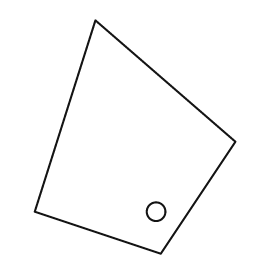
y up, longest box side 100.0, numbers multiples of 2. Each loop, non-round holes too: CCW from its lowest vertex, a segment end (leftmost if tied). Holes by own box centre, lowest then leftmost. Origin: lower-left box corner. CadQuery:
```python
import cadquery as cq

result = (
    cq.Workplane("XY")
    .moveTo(54.0, 0.0)
    .lineTo(86.0, 48.0)
    .lineTo(26.0, 100.0)
    .lineTo(0.0, 18.0)
    .close()
    .moveTo(52.0, 18.0)
    .circle(4.0)
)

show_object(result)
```